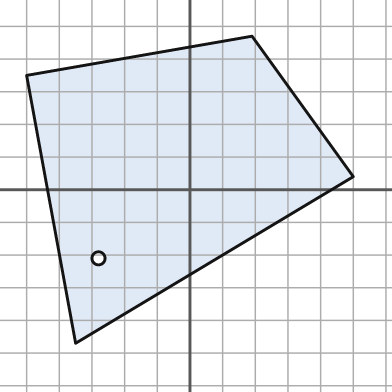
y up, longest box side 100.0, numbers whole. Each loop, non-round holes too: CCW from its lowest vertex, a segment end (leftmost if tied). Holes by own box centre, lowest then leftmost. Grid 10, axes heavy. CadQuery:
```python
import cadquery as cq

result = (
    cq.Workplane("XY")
    .moveTo(-35.0, -47.0)
    .lineTo(50.0, 4.0)
    .lineTo(19.0, 47.0)
    .lineTo(-50.0, 35.0)
    .close()
    .moveTo(-28.0, -21.0)
    .circle(2.0)
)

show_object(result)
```